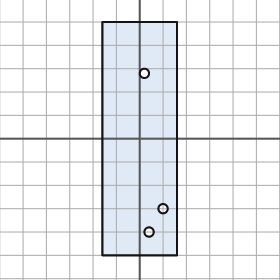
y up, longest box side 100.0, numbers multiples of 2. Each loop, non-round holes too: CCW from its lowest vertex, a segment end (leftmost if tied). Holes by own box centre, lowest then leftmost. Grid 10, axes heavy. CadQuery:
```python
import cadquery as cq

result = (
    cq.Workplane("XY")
    .moveTo(-16.0, -50.0)
    .lineTo(16.0, -50.0)
    .lineTo(16.0, 50.0)
    .lineTo(-16.0, 50.0)
    .close()
    .moveTo(4.0, -40.0)
    .circle(2.0)
    .moveTo(10.0, -30.0)
    .circle(2.0)
    .moveTo(2.0, 28.0)
    .circle(2.0)
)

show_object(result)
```